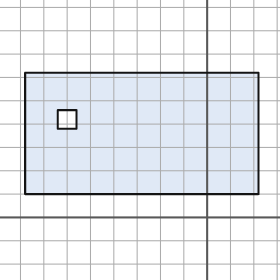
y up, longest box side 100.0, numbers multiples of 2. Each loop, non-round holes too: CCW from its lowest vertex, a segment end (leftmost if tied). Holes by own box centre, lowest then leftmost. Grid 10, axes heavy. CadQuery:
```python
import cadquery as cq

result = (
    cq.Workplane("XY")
    .moveTo(-78.0, 10.0)
    .lineTo(22.0, 10.0)
    .lineTo(22.0, 62.0)
    .lineTo(-78.0, 62.0)
    .close()
    .moveTo(-64.0, 38.0)
    .lineTo(-56.0, 38.0)
    .lineTo(-56.0, 46.0)
    .lineTo(-64.0, 46.0)
    .close()
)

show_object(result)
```